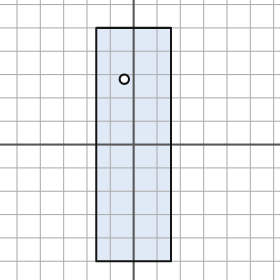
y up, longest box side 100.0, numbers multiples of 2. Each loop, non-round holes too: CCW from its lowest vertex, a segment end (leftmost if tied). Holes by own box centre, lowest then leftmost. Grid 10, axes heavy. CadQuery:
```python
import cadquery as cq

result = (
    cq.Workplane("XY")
    .moveTo(-16.0, -50.0)
    .lineTo(16.0, -50.0)
    .lineTo(16.0, 50.0)
    .lineTo(-16.0, 50.0)
    .close()
    .moveTo(-4.0, 28.0)
    .circle(2.0)
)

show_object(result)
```